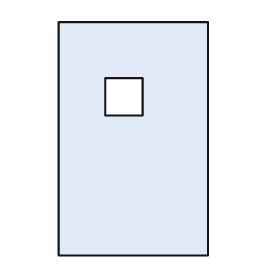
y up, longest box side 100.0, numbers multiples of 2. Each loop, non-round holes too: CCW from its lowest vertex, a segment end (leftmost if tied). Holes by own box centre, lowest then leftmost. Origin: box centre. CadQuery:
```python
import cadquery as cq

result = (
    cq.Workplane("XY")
    .moveTo(-32.0, -50.0)
    .lineTo(32.0, -50.0)
    .lineTo(32.0, 50.0)
    .lineTo(-32.0, 50.0)
    .close()
    .moveTo(-12.0, 10.0)
    .lineTo(4.0, 10.0)
    .lineTo(4.0, 26.0)
    .lineTo(-12.0, 26.0)
    .close()
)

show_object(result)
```